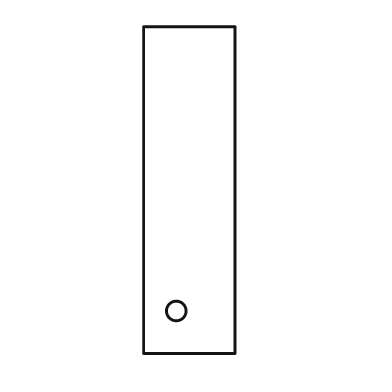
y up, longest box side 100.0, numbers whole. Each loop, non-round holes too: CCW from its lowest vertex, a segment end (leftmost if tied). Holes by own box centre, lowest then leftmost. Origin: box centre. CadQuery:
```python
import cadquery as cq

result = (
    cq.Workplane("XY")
    .moveTo(-14.0, -50.0)
    .lineTo(14.0, -50.0)
    .lineTo(14.0, 50.0)
    .lineTo(-14.0, 50.0)
    .close()
    .moveTo(-4.0, -37.0)
    .circle(3.0)
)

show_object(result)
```